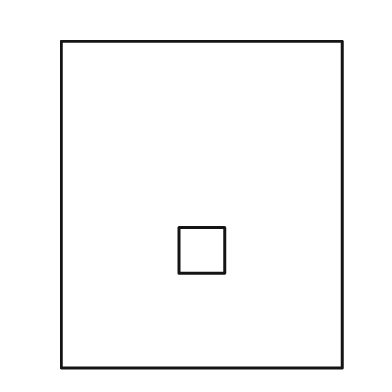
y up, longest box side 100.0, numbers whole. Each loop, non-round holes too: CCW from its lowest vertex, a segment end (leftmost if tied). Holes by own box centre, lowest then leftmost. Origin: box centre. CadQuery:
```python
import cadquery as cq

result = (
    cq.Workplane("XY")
    .moveTo(-43.0, -50.0)
    .lineTo(43.0, -50.0)
    .lineTo(43.0, 50.0)
    .lineTo(-43.0, 50.0)
    .close()
    .moveTo(-7.0, -21.0)
    .lineTo(7.0, -21.0)
    .lineTo(7.0, -7.0)
    .lineTo(-7.0, -7.0)
    .close()
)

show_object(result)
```